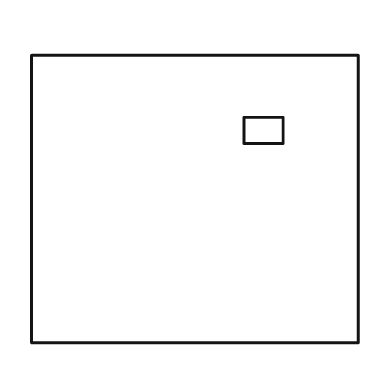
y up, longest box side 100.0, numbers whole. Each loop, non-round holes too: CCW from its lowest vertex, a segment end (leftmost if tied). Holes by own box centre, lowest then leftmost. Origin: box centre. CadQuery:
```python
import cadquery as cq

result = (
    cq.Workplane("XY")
    .moveTo(-50.0, -44.0)
    .lineTo(50.0, -44.0)
    .lineTo(50.0, 44.0)
    .lineTo(-50.0, 44.0)
    .close()
    .moveTo(15.0, 17.0)
    .lineTo(27.0, 17.0)
    .lineTo(27.0, 25.0)
    .lineTo(15.0, 25.0)
    .close()
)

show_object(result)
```